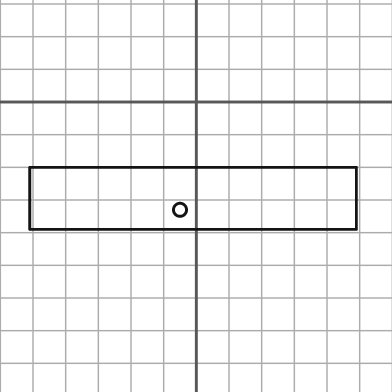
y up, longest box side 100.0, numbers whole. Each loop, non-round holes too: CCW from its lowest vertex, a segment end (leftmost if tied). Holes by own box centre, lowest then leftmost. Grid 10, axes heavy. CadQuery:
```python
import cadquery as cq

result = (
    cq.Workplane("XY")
    .moveTo(-51.0, -39.0)
    .lineTo(49.0, -39.0)
    .lineTo(49.0, -20.0)
    .lineTo(-51.0, -20.0)
    .close()
    .moveTo(-5.0, -33.0)
    .circle(2.0)
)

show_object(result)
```